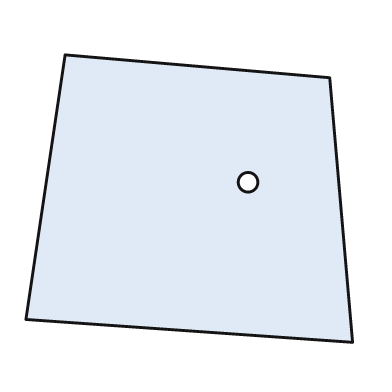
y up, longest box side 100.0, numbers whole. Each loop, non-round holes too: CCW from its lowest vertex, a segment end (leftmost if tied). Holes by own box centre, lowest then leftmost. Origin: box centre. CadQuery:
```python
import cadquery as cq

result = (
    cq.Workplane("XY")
    .moveTo(50.0, -44.0)
    .lineTo(43.0, 37.0)
    .lineTo(-38.0, 44.0)
    .lineTo(-50.0, -37.0)
    .close()
    .moveTo(18.0, 5.0)
    .circle(3.0)
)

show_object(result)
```